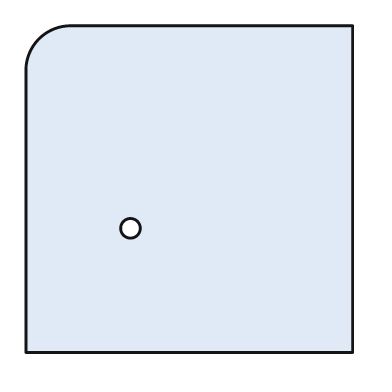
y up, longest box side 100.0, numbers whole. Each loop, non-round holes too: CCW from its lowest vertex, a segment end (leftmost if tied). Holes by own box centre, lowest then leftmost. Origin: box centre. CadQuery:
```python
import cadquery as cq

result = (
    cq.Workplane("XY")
    .moveTo(-50.0, -50.0)
    .lineTo(50.0, -50.0)
    .lineTo(50.0, 50.0)
    .lineTo(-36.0, 50.0)
    .threePointArc((-46.0, 46.0), (-50.0, 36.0))
    .close()
    .moveTo(-18.0, -12.0)
    .circle(3.0)
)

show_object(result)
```